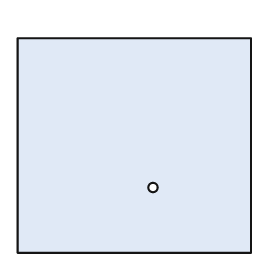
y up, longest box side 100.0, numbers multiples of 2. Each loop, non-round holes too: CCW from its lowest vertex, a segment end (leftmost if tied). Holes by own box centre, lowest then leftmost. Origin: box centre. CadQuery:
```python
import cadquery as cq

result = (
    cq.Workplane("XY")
    .moveTo(-50.0, -46.0)
    .lineTo(50.0, -46.0)
    .lineTo(50.0, 46.0)
    .lineTo(-50.0, 46.0)
    .close()
    .moveTo(8.0, -18.0)
    .circle(2.0)
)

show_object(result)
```